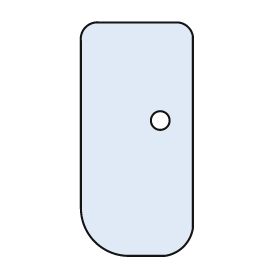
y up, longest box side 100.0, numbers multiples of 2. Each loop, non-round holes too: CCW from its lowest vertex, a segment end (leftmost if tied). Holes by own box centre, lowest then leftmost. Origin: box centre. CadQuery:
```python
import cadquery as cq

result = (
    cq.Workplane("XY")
    .moveTo(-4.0, -50.0)
    .lineTo(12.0, -50.0)
    .threePointArc((20.0, -46.0), (24.0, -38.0))
    .lineTo(24.0, 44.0)
    .threePointArc((22.0, 48.0), (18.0, 50.0))
    .lineTo(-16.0, 50.0)
    .threePointArc((-22.0, 48.0), (-24.0, 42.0))
    .lineTo(-24.0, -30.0)
    .threePointArc((-18.0, -44.0), (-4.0, -50.0))
    .close()
    .moveTo(10.0, 8.0)
    .circle(4.0)
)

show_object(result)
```